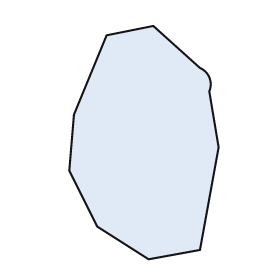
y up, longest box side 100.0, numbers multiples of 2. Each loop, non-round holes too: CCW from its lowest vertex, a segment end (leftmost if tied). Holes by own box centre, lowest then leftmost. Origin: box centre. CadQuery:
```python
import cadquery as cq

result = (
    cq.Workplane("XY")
    .moveTo(2.0, -50.0)
    .lineTo(24.0, -46.0)
    .lineTo(32.0, -2.0)
    .lineTo(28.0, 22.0)
    .threePointArc((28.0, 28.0), (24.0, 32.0))
    .lineTo(4.0, 50.0)
    .lineTo(-16.0, 46.0)
    .lineTo(-30.0, 12.0)
    .lineTo(-32.0, -12.0)
    .lineTo(-20.0, -36.0)
    .close()
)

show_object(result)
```